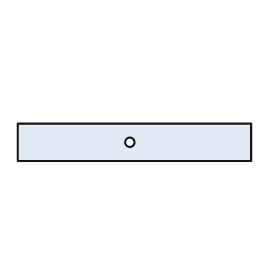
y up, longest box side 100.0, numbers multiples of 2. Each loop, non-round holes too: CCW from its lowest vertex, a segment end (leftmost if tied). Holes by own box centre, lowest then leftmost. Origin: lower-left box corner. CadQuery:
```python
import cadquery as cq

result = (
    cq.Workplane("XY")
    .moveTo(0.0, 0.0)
    .lineTo(100.0, 0.0)
    .lineTo(100.0, 16.0)
    .lineTo(0.0, 16.0)
    .close()
    .moveTo(48.0, 8.0)
    .circle(2.0)
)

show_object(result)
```